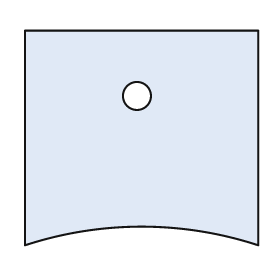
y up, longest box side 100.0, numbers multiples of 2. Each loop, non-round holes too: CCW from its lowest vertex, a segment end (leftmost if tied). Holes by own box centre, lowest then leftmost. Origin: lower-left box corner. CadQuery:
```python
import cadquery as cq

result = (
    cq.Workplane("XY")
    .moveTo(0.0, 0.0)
    .threePointArc((50.0, 8.0), (100.0, 0.0))
    .lineTo(100.0, 92.0)
    .lineTo(0.0, 92.0)
    .close()
    .moveTo(48.0, 64.0)
    .circle(6.0)
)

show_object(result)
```